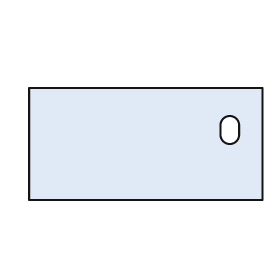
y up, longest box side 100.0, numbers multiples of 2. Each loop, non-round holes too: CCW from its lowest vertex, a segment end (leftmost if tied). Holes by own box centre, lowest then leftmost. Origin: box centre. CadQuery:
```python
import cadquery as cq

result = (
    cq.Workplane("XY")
    .moveTo(-50.0, -24.0)
    .lineTo(50.0, -24.0)
    .lineTo(50.0, 24.0)
    .lineTo(-50.0, 24.0)
    .close()
    .moveTo(32.0, 4.0)
    .threePointArc((36.0, 0.0), (40.0, 4.0))
    .lineTo(40.0, 8.0)
    .threePointArc((36.0, 12.0), (32.0, 8.0))
    .close()
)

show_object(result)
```